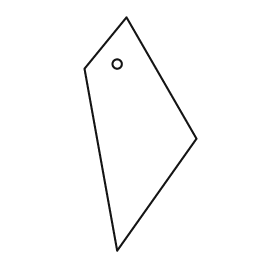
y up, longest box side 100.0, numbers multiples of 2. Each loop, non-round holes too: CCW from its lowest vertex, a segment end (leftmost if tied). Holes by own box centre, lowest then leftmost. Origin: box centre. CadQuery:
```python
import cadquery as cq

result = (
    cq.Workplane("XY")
    .moveTo(-10.0, -50.0)
    .lineTo(24.0, -2.0)
    .lineTo(-6.0, 50.0)
    .lineTo(-24.0, 28.0)
    .close()
    .moveTo(-10.0, 30.0)
    .circle(2.0)
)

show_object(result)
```